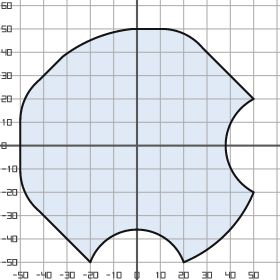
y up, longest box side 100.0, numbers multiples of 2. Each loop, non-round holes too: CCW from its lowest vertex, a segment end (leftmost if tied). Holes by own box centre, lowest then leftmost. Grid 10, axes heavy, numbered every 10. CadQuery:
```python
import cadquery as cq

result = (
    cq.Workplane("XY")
    .moveTo(-20.0, -50.0)
    .threePointArc((0.0, -36.0), (20.0, -50.0))
    .threePointArc((38.0, -38.0), (50.0, -20.0))
    .threePointArc((38.0, 0.0), (50.0, 20.0))
    .lineTo(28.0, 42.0)
    .threePointArc((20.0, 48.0), (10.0, 50.0))
    .lineTo(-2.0, 50.0)
    .threePointArc((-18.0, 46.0), (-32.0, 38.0))
    .lineTo(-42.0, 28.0)
    .threePointArc((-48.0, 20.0), (-50.0, 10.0))
    .lineTo(-50.0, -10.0)
    .threePointArc((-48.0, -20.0), (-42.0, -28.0))
    .close()
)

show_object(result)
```